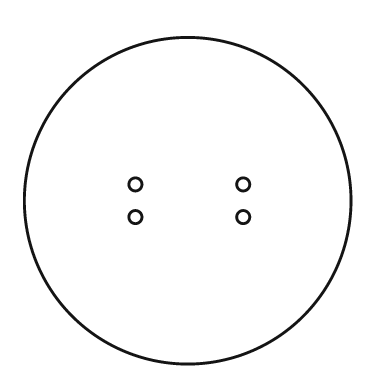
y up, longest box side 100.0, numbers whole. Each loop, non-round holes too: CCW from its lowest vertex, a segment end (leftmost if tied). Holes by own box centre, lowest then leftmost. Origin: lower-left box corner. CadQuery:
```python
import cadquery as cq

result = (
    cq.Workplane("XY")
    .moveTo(50.0, 50.0)
    .circle(50.0)
    .moveTo(34.0, 45.0)
    .circle(2.0)
    .moveTo(67.0, 45.0)
    .circle(2.0)
    .moveTo(34.0, 55.0)
    .circle(2.0)
    .moveTo(67.0, 55.0)
    .circle(2.0)
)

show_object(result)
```